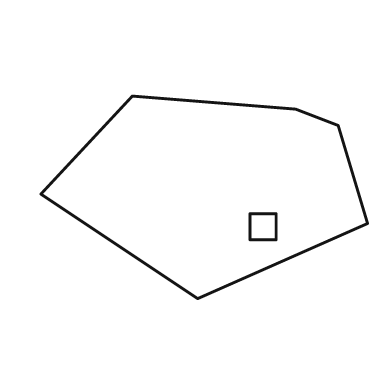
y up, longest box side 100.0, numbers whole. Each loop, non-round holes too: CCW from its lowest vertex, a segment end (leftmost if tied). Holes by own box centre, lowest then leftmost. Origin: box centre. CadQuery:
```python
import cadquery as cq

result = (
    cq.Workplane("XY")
    .moveTo(-2.0, -31.0)
    .lineTo(50.0, -8.0)
    .lineTo(41.0, 22.0)
    .lineTo(28.0, 27.0)
    .lineTo(-22.0, 31.0)
    .lineTo(-50.0, 1.0)
    .close()
    .moveTo(14.0, -13.0)
    .lineTo(22.0, -13.0)
    .lineTo(22.0, -5.0)
    .lineTo(14.0, -5.0)
    .close()
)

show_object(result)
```